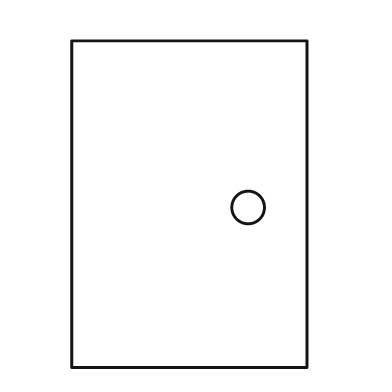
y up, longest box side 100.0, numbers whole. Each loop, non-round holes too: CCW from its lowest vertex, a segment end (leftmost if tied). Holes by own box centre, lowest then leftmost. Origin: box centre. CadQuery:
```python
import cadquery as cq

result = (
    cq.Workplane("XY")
    .moveTo(-36.0, -50.0)
    .lineTo(36.0, -50.0)
    .lineTo(36.0, 50.0)
    .lineTo(-36.0, 50.0)
    .close()
    .moveTo(18.0, -1.0)
    .circle(5.0)
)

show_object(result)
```